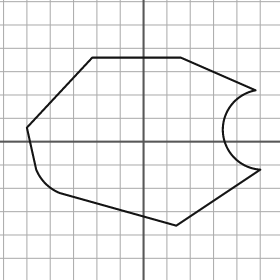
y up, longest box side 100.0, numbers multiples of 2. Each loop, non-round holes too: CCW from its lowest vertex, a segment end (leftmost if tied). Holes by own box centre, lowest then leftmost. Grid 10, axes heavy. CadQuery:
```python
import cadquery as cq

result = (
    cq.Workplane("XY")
    .moveTo(14.0, -36.0)
    .lineTo(50.0, -12.0)
    .threePointArc((34.0, 4.0), (48.0, 22.0))
    .lineTo(16.0, 36.0)
    .lineTo(-22.0, 36.0)
    .lineTo(-50.0, 6.0)
    .lineTo(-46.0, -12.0)
    .threePointArc((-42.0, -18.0), (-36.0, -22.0))
    .close()
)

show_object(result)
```